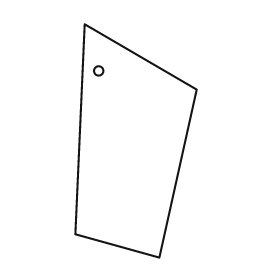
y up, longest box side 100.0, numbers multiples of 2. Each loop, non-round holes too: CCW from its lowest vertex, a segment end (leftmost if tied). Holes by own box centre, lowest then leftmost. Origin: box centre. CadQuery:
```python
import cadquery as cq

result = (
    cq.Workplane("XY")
    .moveTo(10.0, -50.0)
    .lineTo(26.0, 22.0)
    .lineTo(-22.0, 50.0)
    .lineTo(-26.0, -40.0)
    .close()
    .moveTo(-16.0, 30.0)
    .circle(2.0)
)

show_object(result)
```